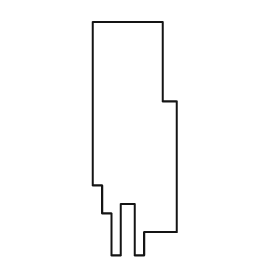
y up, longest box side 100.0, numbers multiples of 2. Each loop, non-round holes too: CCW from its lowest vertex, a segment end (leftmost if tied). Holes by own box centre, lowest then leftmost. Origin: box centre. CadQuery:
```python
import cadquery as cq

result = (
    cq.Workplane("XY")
    .moveTo(-10.0, -50.0)
    .lineTo(-6.0, -50.0)
    .lineTo(-6.0, -28.0)
    .lineTo(0.0, -28.0)
    .lineTo(0.0, -50.0)
    .lineTo(4.0, -50.0)
    .lineTo(4.0, -40.0)
    .lineTo(18.0, -40.0)
    .lineTo(18.0, 16.0)
    .lineTo(12.0, 16.0)
    .lineTo(12.0, 50.0)
    .lineTo(-18.0, 50.0)
    .lineTo(-18.0, -20.0)
    .lineTo(-14.0, -20.0)
    .lineTo(-14.0, -32.0)
    .lineTo(-10.0, -32.0)
    .close()
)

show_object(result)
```